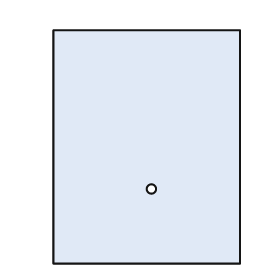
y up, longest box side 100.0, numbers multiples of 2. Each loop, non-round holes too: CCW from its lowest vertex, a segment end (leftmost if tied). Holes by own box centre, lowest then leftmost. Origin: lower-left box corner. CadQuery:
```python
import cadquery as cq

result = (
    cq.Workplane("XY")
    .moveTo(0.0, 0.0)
    .lineTo(80.0, 0.0)
    .lineTo(80.0, 100.0)
    .lineTo(0.0, 100.0)
    .close()
    .moveTo(42.0, 32.0)
    .circle(2.0)
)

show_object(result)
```